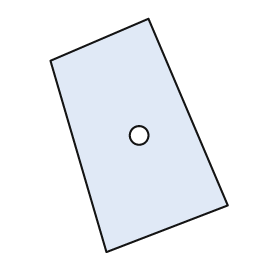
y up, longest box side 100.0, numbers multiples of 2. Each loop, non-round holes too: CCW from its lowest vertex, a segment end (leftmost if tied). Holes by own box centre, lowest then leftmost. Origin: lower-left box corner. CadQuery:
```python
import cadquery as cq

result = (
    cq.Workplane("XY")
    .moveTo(24.0, 0.0)
    .lineTo(76.0, 20.0)
    .lineTo(42.0, 100.0)
    .lineTo(0.0, 82.0)
    .close()
    .moveTo(38.0, 50.0)
    .circle(4.0)
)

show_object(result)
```